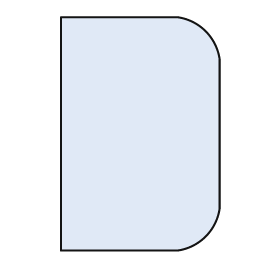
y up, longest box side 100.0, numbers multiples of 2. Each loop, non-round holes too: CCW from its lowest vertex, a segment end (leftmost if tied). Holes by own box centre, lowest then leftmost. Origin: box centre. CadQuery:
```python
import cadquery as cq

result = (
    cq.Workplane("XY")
    .moveTo(-34.0, -50.0)
    .lineTo(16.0, -50.0)
    .threePointArc((28.0, -44.0), (34.0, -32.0))
    .lineTo(34.0, 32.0)
    .threePointArc((28.0, 44.0), (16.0, 50.0))
    .lineTo(-34.0, 50.0)
    .close()
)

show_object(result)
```